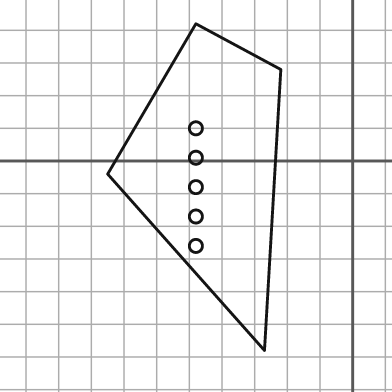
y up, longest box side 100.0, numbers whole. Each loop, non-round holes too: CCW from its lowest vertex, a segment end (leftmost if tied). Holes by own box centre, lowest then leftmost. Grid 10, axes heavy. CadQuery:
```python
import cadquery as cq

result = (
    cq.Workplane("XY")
    .moveTo(-27.0, -58.0)
    .lineTo(-22.0, 28.0)
    .lineTo(-48.0, 42.0)
    .lineTo(-75.0, -4.0)
    .close()
    .moveTo(-48.0, -26.0)
    .circle(2.0)
    .moveTo(-48.0, -17.0)
    .circle(2.0)
    .moveTo(-48.0, -8.0)
    .circle(2.0)
    .moveTo(-48.0, 1.0)
    .circle(2.0)
    .moveTo(-48.0, 10.0)
    .circle(2.0)
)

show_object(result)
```